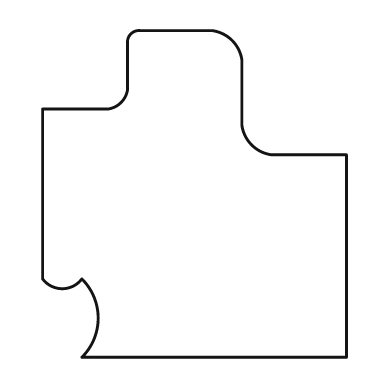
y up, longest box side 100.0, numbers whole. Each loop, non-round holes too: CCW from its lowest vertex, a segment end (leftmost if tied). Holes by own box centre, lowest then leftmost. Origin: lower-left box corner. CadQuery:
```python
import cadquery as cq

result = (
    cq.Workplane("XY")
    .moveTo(12.0, 0.0)
    .lineTo(93.0, 0.0)
    .lineTo(93.0, 62.0)
    .lineTo(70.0, 62.0)
    .threePointArc((64.0, 65.0), (61.0, 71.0))
    .lineTo(61.0, 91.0)
    .threePointArc((58.0, 97.0), (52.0, 100.0))
    .lineTo(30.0, 100.0)
    .threePointArc((27.0, 99.0), (26.0, 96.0))
    .lineTo(26.0, 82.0)
    .threePointArc((24.0, 78.0), (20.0, 76.0))
    .lineTo(0.0, 76.0)
    .lineTo(0.0, 24.0)
    .threePointArc((6.0, 21.0), (12.0, 24.0))
    .threePointArc((17.0, 12.0), (12.0, 0.0))
    .close()
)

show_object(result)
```